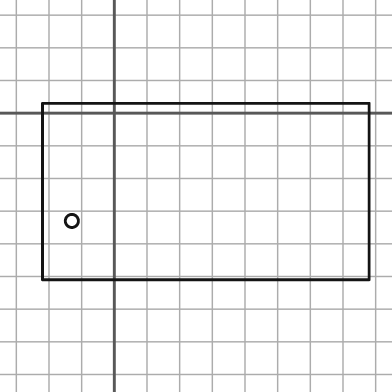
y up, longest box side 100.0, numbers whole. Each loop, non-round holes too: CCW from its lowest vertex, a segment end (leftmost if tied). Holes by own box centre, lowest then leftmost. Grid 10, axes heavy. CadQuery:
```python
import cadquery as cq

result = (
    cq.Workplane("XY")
    .moveTo(-22.0, -51.0)
    .lineTo(78.0, -51.0)
    .lineTo(78.0, 3.0)
    .lineTo(-22.0, 3.0)
    .close()
    .moveTo(-13.0, -33.0)
    .circle(2.0)
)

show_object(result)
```